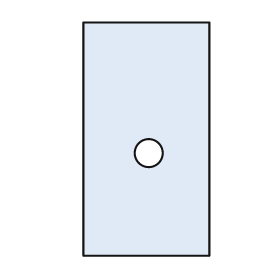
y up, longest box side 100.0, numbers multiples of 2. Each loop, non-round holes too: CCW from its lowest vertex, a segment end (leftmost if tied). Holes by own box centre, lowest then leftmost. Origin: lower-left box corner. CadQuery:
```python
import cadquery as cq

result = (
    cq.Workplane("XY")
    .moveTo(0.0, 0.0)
    .lineTo(54.0, 0.0)
    .lineTo(54.0, 100.0)
    .lineTo(0.0, 100.0)
    .close()
    .moveTo(28.0, 44.0)
    .circle(6.0)
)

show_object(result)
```